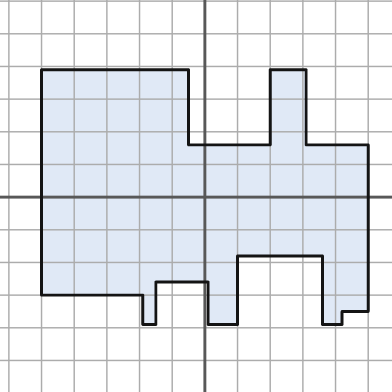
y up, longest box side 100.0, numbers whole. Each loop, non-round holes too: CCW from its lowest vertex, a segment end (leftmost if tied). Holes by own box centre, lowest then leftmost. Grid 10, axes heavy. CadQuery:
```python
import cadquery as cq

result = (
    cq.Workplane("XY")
    .moveTo(-19.0, -39.0)
    .lineTo(-15.0, -39.0)
    .lineTo(-15.0, -26.0)
    .lineTo(1.0, -26.0)
    .lineTo(1.0, -39.0)
    .lineTo(10.0, -39.0)
    .lineTo(10.0, -18.0)
    .lineTo(36.0, -18.0)
    .lineTo(36.0, -39.0)
    .lineTo(42.0, -39.0)
    .lineTo(42.0, -35.0)
    .lineTo(50.0, -35.0)
    .lineTo(50.0, 16.0)
    .lineTo(31.0, 16.0)
    .lineTo(31.0, 39.0)
    .lineTo(20.0, 39.0)
    .lineTo(20.0, 16.0)
    .lineTo(-5.0, 16.0)
    .lineTo(-5.0, 39.0)
    .lineTo(-50.0, 39.0)
    .lineTo(-50.0, -30.0)
    .lineTo(-19.0, -30.0)
    .close()
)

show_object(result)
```